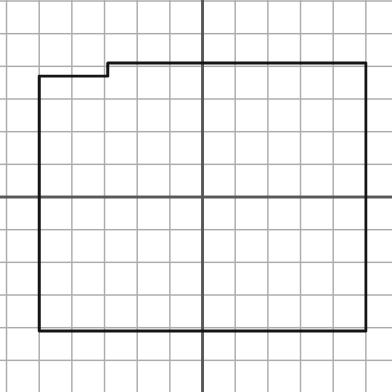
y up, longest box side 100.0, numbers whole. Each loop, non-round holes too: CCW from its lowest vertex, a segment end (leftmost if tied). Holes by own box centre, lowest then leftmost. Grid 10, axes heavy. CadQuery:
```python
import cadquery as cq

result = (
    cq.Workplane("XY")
    .moveTo(-50.0, -41.0)
    .lineTo(50.0, -41.0)
    .lineTo(50.0, 41.0)
    .lineTo(-29.0, 41.0)
    .lineTo(-29.0, 37.0)
    .lineTo(-50.0, 37.0)
    .close()
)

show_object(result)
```